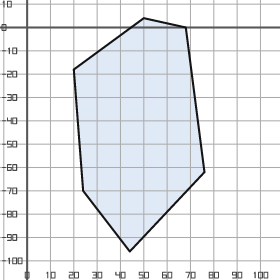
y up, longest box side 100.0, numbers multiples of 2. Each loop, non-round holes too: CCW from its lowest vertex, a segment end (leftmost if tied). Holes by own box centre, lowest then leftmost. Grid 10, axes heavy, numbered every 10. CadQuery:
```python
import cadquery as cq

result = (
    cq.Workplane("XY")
    .moveTo(44.0, -96.0)
    .lineTo(76.0, -62.0)
    .lineTo(68.0, 0.0)
    .lineTo(50.0, 4.0)
    .lineTo(20.0, -18.0)
    .lineTo(24.0, -70.0)
    .close()
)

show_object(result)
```